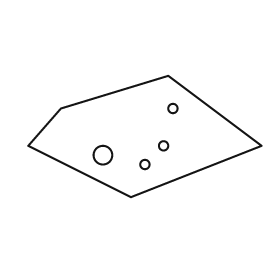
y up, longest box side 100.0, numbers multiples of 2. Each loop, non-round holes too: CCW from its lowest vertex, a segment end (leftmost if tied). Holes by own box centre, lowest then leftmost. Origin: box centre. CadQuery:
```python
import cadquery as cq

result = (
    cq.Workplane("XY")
    .moveTo(-6.0, -26.0)
    .lineTo(50.0, -4.0)
    .lineTo(10.0, 26.0)
    .lineTo(-36.0, 12.0)
    .lineTo(-50.0, -4.0)
    .close()
    .moveTo(0.0, -12.0)
    .circle(2.0)
    .moveTo(-18.0, -8.0)
    .circle(4.0)
    .moveTo(8.0, -4.0)
    .circle(2.0)
    .moveTo(12.0, 12.0)
    .circle(2.0)
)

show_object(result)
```